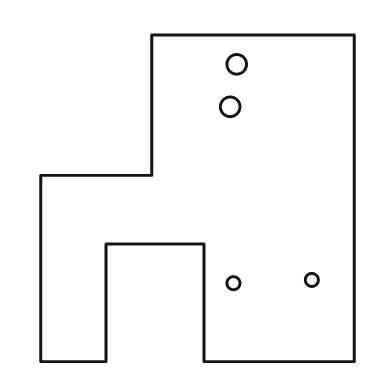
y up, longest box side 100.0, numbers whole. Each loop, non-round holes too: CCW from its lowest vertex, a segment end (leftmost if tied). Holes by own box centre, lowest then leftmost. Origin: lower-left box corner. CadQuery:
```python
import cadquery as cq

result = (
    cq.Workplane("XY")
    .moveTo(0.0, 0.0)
    .lineTo(20.0, 0.0)
    .lineTo(20.0, 36.0)
    .lineTo(50.0, 36.0)
    .lineTo(50.0, 0.0)
    .lineTo(96.0, 0.0)
    .lineTo(96.0, 100.0)
    .lineTo(34.0, 100.0)
    .lineTo(34.0, 57.0)
    .lineTo(0.0, 57.0)
    .close()
    .moveTo(59.0, 24.0)
    .circle(2.0)
    .moveTo(83.0, 25.0)
    .circle(2.0)
    .moveTo(58.0, 78.0)
    .circle(3.0)
    .moveTo(60.0, 91.0)
    .circle(3.0)
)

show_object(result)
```